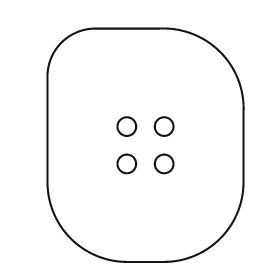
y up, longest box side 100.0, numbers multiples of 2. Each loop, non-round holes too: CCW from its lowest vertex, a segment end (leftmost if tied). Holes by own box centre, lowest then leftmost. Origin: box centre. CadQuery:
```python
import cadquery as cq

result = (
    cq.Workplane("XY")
    .moveTo(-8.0, -50.0)
    .lineTo(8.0, -50.0)
    .threePointArc((32.0, -40.0), (42.0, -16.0))
    .lineTo(42.0, 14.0)
    .threePointArc((32.0, 40.0), (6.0, 50.0))
    .lineTo(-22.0, 50.0)
    .threePointArc((-36.0, 44.0), (-42.0, 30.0))
    .lineTo(-42.0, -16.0)
    .threePointArc((-32.0, -40.0), (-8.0, -50.0))
    .close()
    .moveTo(-8.0, -8.0)
    .circle(4.0)
    .moveTo(8.0, -8.0)
    .circle(4.0)
    .moveTo(-8.0, 8.0)
    .circle(4.0)
    .moveTo(8.0, 8.0)
    .circle(4.0)
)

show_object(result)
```